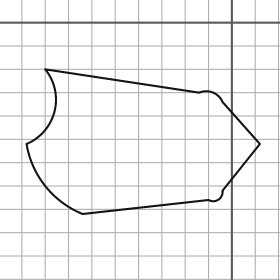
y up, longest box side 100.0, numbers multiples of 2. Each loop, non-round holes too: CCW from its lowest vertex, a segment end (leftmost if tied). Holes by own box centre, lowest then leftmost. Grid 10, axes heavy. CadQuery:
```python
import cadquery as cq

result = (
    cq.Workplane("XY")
    .moveTo(-64.0, -82.0)
    .lineTo(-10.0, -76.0)
    .threePointArc((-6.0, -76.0), (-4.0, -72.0))
    .lineTo(12.0, -52.0)
    .lineTo(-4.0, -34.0)
    .threePointArc((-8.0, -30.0), (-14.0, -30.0))
    .lineTo(-80.0, -20.0)
    .threePointArc((-76.0, -38.0), (-88.0, -52.0))
    .threePointArc((-80.0, -70.0), (-64.0, -82.0))
    .close()
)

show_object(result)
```